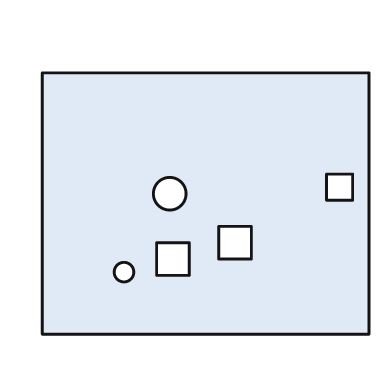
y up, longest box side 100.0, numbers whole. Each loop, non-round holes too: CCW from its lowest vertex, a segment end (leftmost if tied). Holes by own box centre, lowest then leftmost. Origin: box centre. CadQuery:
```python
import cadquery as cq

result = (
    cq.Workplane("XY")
    .moveTo(-50.0, -40.0)
    .lineTo(50.0, -40.0)
    .lineTo(50.0, 40.0)
    .lineTo(-50.0, 40.0)
    .close()
    .moveTo(-25.0, -21.0)
    .circle(3.0)
    .moveTo(-15.0, -22.0)
    .lineTo(-5.0, -22.0)
    .lineTo(-5.0, -12.0)
    .lineTo(-15.0, -12.0)
    .close()
    .moveTo(4.0, -17.0)
    .lineTo(14.0, -17.0)
    .lineTo(14.0, -7.0)
    .lineTo(4.0, -7.0)
    .close()
    .moveTo(-11.0, 3.0)
    .circle(5.0)
    .moveTo(37.0, 1.0)
    .lineTo(45.0, 1.0)
    .lineTo(45.0, 9.0)
    .lineTo(37.0, 9.0)
    .close()
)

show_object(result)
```